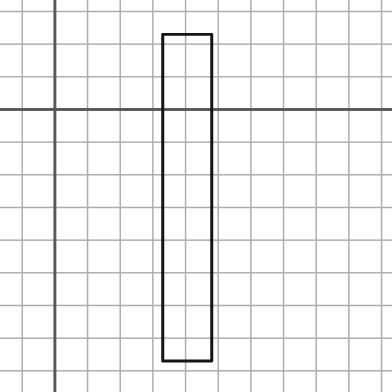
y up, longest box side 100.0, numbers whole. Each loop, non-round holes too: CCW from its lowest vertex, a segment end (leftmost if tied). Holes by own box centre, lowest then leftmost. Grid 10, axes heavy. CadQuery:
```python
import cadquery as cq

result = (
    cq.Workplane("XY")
    .moveTo(33.0, -77.0)
    .lineTo(48.0, -77.0)
    .lineTo(48.0, 23.0)
    .lineTo(33.0, 23.0)
    .close()
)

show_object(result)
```